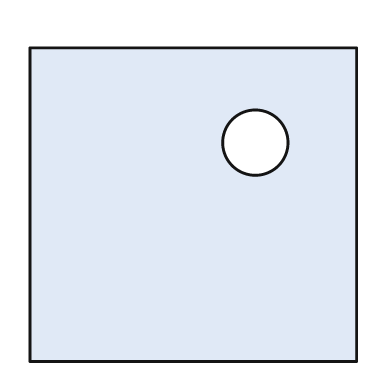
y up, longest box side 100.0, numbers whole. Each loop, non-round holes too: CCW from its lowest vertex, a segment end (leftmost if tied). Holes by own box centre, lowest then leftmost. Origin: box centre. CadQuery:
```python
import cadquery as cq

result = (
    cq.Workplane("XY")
    .moveTo(-50.0, -48.0)
    .lineTo(50.0, -48.0)
    .lineTo(50.0, 48.0)
    .lineTo(-50.0, 48.0)
    .close()
    .moveTo(19.0, 19.0)
    .circle(10.0)
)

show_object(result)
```